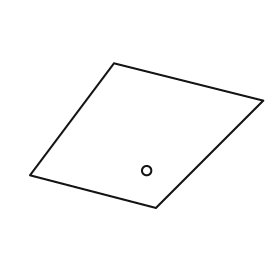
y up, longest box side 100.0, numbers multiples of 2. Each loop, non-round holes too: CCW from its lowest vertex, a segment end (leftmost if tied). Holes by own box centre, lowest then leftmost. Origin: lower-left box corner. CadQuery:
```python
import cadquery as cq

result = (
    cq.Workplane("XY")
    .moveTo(54.0, 0.0)
    .lineTo(100.0, 46.0)
    .lineTo(36.0, 62.0)
    .lineTo(0.0, 14.0)
    .close()
    .moveTo(50.0, 16.0)
    .circle(2.0)
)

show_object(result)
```